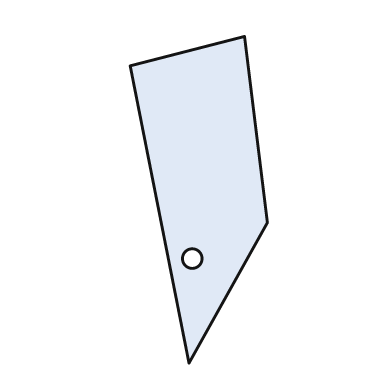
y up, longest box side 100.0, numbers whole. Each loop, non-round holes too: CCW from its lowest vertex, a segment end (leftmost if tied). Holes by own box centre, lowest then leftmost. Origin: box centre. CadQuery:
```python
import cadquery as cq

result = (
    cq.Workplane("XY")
    .moveTo(-3.0, -50.0)
    .lineTo(21.0, -7.0)
    .lineTo(14.0, 50.0)
    .lineTo(-21.0, 41.0)
    .close()
    .moveTo(-2.0, -18.0)
    .circle(3.0)
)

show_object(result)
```